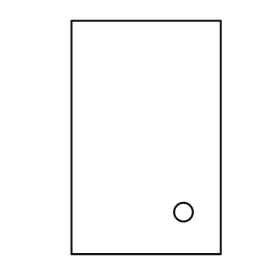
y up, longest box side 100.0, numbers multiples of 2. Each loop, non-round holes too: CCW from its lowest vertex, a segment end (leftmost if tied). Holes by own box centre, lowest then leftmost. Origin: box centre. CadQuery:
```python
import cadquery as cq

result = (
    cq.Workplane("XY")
    .moveTo(-32.0, -50.0)
    .lineTo(32.0, -50.0)
    .lineTo(32.0, 50.0)
    .lineTo(-32.0, 50.0)
    .close()
    .moveTo(16.0, -32.0)
    .circle(4.0)
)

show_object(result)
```